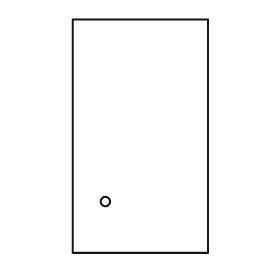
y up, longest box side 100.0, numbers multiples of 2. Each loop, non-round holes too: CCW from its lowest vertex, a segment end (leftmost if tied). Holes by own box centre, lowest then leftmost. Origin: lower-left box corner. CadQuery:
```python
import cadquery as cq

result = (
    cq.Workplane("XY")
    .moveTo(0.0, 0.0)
    .lineTo(58.0, 0.0)
    .lineTo(58.0, 100.0)
    .lineTo(0.0, 100.0)
    .close()
    .moveTo(14.0, 22.0)
    .circle(2.0)
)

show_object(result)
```